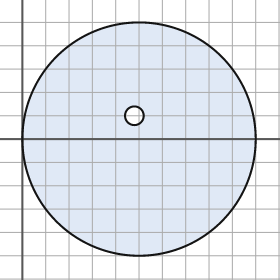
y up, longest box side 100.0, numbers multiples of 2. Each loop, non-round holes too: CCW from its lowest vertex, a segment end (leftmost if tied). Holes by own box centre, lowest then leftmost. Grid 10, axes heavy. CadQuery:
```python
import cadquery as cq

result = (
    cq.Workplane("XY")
    .moveTo(50.0, 0.0)
    .circle(50.0)
    .moveTo(48.0, 10.0)
    .circle(4.0)
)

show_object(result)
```